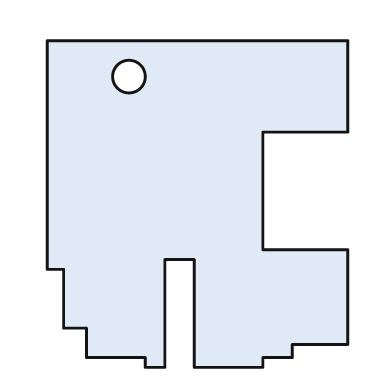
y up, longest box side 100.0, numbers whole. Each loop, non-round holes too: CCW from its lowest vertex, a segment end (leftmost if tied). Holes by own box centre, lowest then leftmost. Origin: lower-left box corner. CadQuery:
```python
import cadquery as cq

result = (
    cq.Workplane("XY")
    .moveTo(30.0, 0.0)
    .lineTo(36.0, 0.0)
    .lineTo(36.0, 33.0)
    .lineTo(45.0, 33.0)
    .lineTo(45.0, 0.0)
    .lineTo(66.0, 0.0)
    .lineTo(66.0, 3.0)
    .lineTo(75.0, 3.0)
    .lineTo(75.0, 7.0)
    .lineTo(92.0, 7.0)
    .lineTo(92.0, 36.0)
    .lineTo(66.0, 36.0)
    .lineTo(66.0, 72.0)
    .lineTo(92.0, 72.0)
    .lineTo(92.0, 100.0)
    .lineTo(0.0, 100.0)
    .lineTo(0.0, 30.0)
    .lineTo(5.0, 30.0)
    .lineTo(5.0, 12.0)
    .lineTo(12.0, 12.0)
    .lineTo(12.0, 3.0)
    .lineTo(30.0, 3.0)
    .close()
    .moveTo(25.0, 89.0)
    .circle(5.0)
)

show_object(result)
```